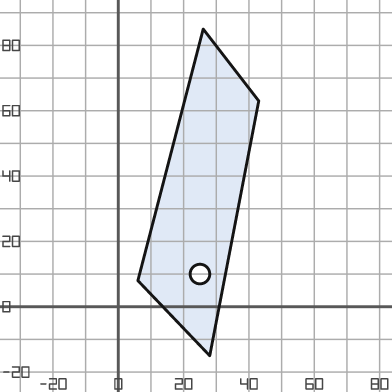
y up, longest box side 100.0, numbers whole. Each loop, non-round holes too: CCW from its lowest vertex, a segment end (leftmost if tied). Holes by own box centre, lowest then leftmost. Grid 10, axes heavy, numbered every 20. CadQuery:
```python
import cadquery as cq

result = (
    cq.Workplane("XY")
    .moveTo(28.0, -15.0)
    .lineTo(43.0, 63.0)
    .lineTo(26.0, 85.0)
    .lineTo(6.0, 8.0)
    .close()
    .moveTo(25.0, 10.0)
    .circle(3.0)
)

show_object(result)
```